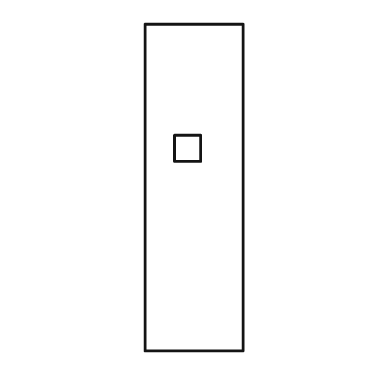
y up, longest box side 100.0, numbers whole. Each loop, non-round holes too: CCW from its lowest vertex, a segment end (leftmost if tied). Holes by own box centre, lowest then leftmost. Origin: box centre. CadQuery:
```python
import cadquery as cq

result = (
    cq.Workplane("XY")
    .moveTo(-15.0, -50.0)
    .lineTo(15.0, -50.0)
    .lineTo(15.0, 50.0)
    .lineTo(-15.0, 50.0)
    .close()
    .moveTo(-6.0, 8.0)
    .lineTo(2.0, 8.0)
    .lineTo(2.0, 16.0)
    .lineTo(-6.0, 16.0)
    .close()
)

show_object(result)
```